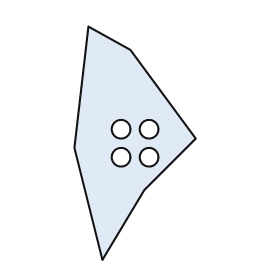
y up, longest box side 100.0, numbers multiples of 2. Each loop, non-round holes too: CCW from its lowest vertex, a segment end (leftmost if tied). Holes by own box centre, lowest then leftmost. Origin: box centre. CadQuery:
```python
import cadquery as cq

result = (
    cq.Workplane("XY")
    .moveTo(-14.0, -50.0)
    .lineTo(4.0, -20.0)
    .lineTo(26.0, 2.0)
    .lineTo(-2.0, 40.0)
    .lineTo(-20.0, 50.0)
    .lineTo(-26.0, -2.0)
    .close()
    .moveTo(-6.0, -6.0)
    .circle(4.0)
    .moveTo(6.0, -6.0)
    .circle(4.0)
    .moveTo(-6.0, 6.0)
    .circle(4.0)
    .moveTo(6.0, 6.0)
    .circle(4.0)
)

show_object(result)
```